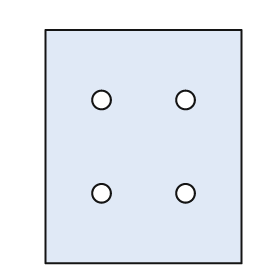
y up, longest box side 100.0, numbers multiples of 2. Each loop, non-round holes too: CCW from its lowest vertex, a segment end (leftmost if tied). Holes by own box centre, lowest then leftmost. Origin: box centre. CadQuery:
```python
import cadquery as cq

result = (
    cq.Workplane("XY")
    .moveTo(-42.0, -50.0)
    .lineTo(42.0, -50.0)
    .lineTo(42.0, 50.0)
    .lineTo(-42.0, 50.0)
    .close()
    .moveTo(-18.0, -20.0)
    .circle(4.0)
    .moveTo(18.0, -20.0)
    .circle(4.0)
    .moveTo(-18.0, 20.0)
    .circle(4.0)
    .moveTo(18.0, 20.0)
    .circle(4.0)
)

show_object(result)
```